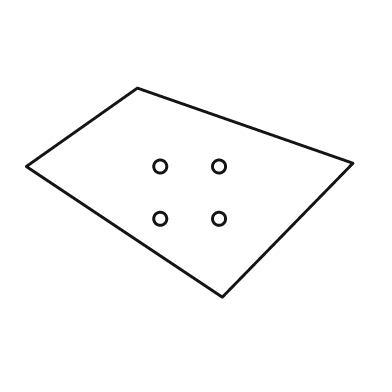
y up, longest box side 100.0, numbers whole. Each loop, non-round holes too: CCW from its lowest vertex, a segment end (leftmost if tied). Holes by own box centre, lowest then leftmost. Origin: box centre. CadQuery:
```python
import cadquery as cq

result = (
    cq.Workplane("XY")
    .moveTo(10.0, -32.0)
    .lineTo(50.0, 9.0)
    .lineTo(-16.0, 32.0)
    .lineTo(-50.0, 8.0)
    .close()
    .moveTo(-9.0, -8.0)
    .circle(2.0)
    .moveTo(9.0, -8.0)
    .circle(2.0)
    .moveTo(-9.0, 8.0)
    .circle(2.0)
    .moveTo(9.0, 8.0)
    .circle(2.0)
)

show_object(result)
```